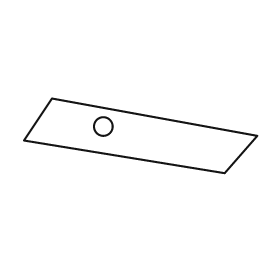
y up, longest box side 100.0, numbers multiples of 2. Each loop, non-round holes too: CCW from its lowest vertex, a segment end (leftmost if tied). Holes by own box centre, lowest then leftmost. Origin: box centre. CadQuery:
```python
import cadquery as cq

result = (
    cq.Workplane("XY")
    .moveTo(36.0, -16.0)
    .lineTo(50.0, 0.0)
    .lineTo(-38.0, 16.0)
    .lineTo(-50.0, -2.0)
    .close()
    .moveTo(-16.0, 4.0)
    .circle(4.0)
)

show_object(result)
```